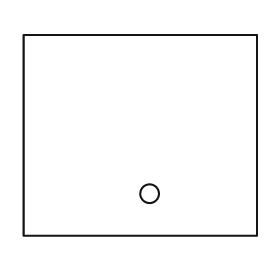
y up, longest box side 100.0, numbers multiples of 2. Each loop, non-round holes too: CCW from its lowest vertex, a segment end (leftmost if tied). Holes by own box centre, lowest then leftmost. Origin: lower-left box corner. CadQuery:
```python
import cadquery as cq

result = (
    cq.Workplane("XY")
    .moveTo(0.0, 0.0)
    .lineTo(100.0, 0.0)
    .lineTo(100.0, 86.0)
    .lineTo(0.0, 86.0)
    .close()
    .moveTo(54.0, 18.0)
    .circle(4.0)
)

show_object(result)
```